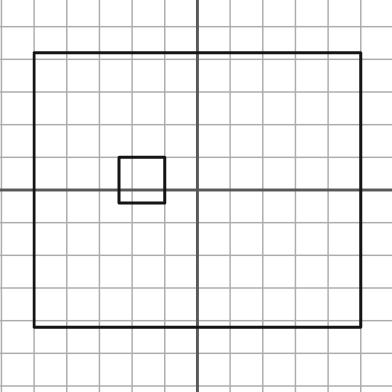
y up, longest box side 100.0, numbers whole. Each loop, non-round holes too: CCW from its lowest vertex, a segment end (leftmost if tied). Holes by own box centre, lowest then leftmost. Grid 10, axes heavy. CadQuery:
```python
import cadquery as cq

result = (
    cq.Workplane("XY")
    .moveTo(-50.0, -42.0)
    .lineTo(50.0, -42.0)
    .lineTo(50.0, 42.0)
    .lineTo(-50.0, 42.0)
    .close()
    .moveTo(-24.0, -4.0)
    .lineTo(-10.0, -4.0)
    .lineTo(-10.0, 10.0)
    .lineTo(-24.0, 10.0)
    .close()
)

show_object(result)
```